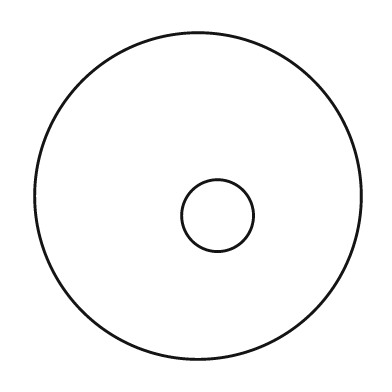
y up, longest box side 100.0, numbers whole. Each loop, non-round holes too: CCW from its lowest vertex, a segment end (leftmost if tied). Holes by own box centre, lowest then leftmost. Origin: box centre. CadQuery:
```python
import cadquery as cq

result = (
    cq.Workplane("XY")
    .moveTo(0.0, 0.0)
    .circle(50.0)
    .moveTo(6.0, -6.0)
    .circle(11.0)
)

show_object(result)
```